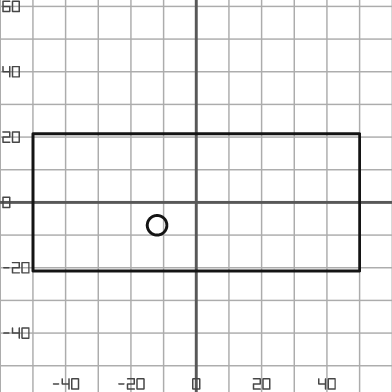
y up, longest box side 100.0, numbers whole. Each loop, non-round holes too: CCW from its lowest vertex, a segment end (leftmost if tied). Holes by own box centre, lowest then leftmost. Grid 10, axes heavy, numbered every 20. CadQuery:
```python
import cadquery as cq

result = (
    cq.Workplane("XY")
    .moveTo(-50.0, -21.0)
    .lineTo(50.0, -21.0)
    .lineTo(50.0, 21.0)
    .lineTo(-50.0, 21.0)
    .close()
    .moveTo(-12.0, -7.0)
    .circle(3.0)
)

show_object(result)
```